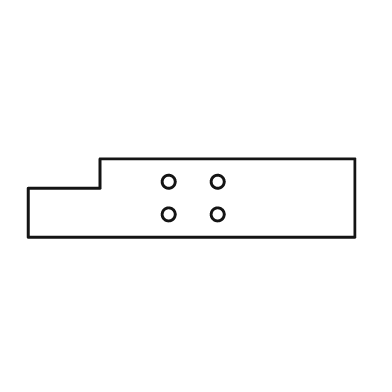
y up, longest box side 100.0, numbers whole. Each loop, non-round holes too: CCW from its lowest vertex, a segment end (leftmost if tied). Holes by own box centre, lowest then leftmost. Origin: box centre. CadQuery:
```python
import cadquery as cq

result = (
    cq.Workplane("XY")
    .moveTo(-50.0, -12.0)
    .lineTo(50.0, -12.0)
    .lineTo(50.0, 12.0)
    .lineTo(-28.0, 12.0)
    .lineTo(-28.0, 3.0)
    .lineTo(-50.0, 3.0)
    .close()
    .moveTo(-7.0, -5.0)
    .circle(2.0)
    .moveTo(8.0, -5.0)
    .circle(2.0)
    .moveTo(-7.0, 5.0)
    .circle(2.0)
    .moveTo(8.0, 5.0)
    .circle(2.0)
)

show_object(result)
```